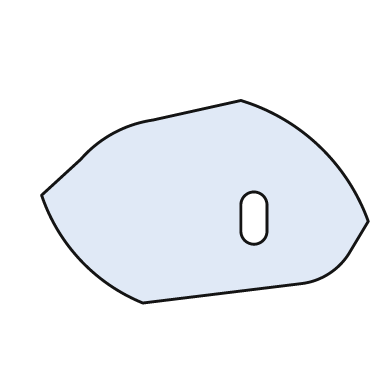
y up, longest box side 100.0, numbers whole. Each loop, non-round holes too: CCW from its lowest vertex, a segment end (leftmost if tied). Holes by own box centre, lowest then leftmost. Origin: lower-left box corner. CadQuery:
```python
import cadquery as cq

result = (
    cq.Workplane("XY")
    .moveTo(31.0, 0.0)
    .lineTo(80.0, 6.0)
    .threePointArc((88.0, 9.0), (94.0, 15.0))
    .lineTo(100.0, 25.0)
    .threePointArc((85.0, 48.0), (61.0, 62.0))
    .lineTo(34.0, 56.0)
    .threePointArc((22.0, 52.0), (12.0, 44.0))
    .lineTo(0.0, 33.0)
    .threePointArc((12.0, 13.0), (31.0, 0.0))
    .close()
    .moveTo(61.0, 22.0)
    .threePointArc((65.0, 18.0), (69.0, 22.0))
    .lineTo(69.0, 30.0)
    .threePointArc((65.0, 34.0), (61.0, 30.0))
    .close()
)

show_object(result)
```